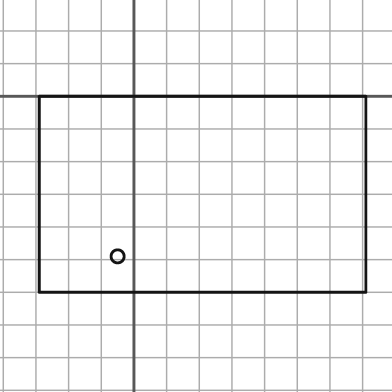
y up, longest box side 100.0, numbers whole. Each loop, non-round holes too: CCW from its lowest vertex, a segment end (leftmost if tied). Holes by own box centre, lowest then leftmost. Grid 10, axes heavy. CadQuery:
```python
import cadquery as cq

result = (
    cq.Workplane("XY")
    .moveTo(-29.0, -60.0)
    .lineTo(71.0, -60.0)
    .lineTo(71.0, 0.0)
    .lineTo(-29.0, 0.0)
    .close()
    .moveTo(-5.0, -49.0)
    .circle(2.0)
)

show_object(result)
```